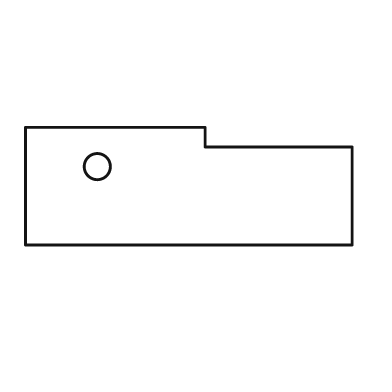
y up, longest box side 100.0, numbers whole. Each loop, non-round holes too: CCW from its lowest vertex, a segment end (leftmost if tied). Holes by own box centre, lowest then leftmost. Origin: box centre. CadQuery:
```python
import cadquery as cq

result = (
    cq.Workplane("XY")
    .moveTo(-50.0, -18.0)
    .lineTo(50.0, -18.0)
    .lineTo(50.0, 12.0)
    .lineTo(5.0, 12.0)
    .lineTo(5.0, 18.0)
    .lineTo(-50.0, 18.0)
    .close()
    .moveTo(-28.0, 6.0)
    .circle(4.0)
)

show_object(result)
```